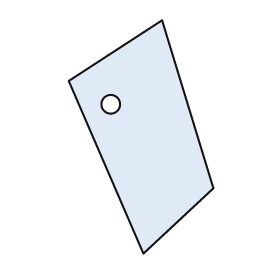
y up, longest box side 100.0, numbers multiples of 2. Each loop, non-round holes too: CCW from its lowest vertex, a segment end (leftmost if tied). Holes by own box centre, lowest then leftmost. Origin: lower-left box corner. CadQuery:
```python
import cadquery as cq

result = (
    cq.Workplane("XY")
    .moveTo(32.0, 0.0)
    .lineTo(62.0, 28.0)
    .lineTo(40.0, 100.0)
    .lineTo(0.0, 74.0)
    .close()
    .moveTo(18.0, 64.0)
    .circle(4.0)
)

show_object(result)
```